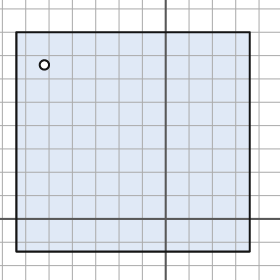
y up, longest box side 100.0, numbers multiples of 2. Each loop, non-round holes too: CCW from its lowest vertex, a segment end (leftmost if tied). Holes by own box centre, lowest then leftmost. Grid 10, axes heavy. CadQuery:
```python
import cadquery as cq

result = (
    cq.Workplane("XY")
    .moveTo(-64.0, -14.0)
    .lineTo(36.0, -14.0)
    .lineTo(36.0, 80.0)
    .lineTo(-64.0, 80.0)
    .close()
    .moveTo(-52.0, 66.0)
    .circle(2.0)
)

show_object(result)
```